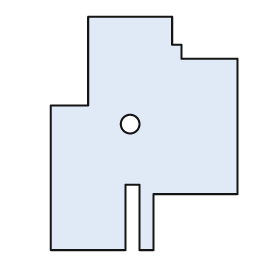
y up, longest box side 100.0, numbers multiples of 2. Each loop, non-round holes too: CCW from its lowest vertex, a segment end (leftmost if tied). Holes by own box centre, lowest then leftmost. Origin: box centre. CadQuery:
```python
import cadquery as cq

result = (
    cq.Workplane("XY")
    .moveTo(-40.0, -50.0)
    .lineTo(-8.0, -50.0)
    .lineTo(-8.0, -22.0)
    .lineTo(-2.0, -22.0)
    .lineTo(-2.0, -50.0)
    .lineTo(4.0, -50.0)
    .lineTo(4.0, -26.0)
    .lineTo(40.0, -26.0)
    .lineTo(40.0, 32.0)
    .lineTo(16.0, 32.0)
    .lineTo(16.0, 38.0)
    .lineTo(12.0, 38.0)
    .lineTo(12.0, 50.0)
    .lineTo(-24.0, 50.0)
    .lineTo(-24.0, 12.0)
    .lineTo(-40.0, 12.0)
    .close()
    .moveTo(-6.0, 4.0)
    .circle(4.0)
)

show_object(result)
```